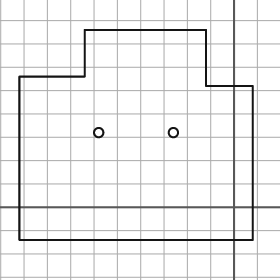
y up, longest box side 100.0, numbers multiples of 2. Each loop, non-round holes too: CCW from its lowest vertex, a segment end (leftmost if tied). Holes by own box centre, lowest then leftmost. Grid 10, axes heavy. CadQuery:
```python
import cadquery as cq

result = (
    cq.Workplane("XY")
    .moveTo(-92.0, -14.0)
    .lineTo(8.0, -14.0)
    .lineTo(8.0, 52.0)
    .lineTo(-12.0, 52.0)
    .lineTo(-12.0, 76.0)
    .lineTo(-64.0, 76.0)
    .lineTo(-64.0, 56.0)
    .lineTo(-92.0, 56.0)
    .close()
    .moveTo(-58.0, 32.0)
    .circle(2.0)
    .moveTo(-26.0, 32.0)
    .circle(2.0)
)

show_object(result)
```